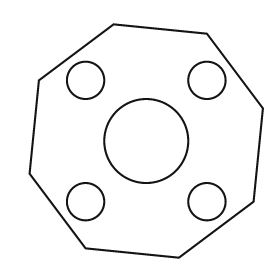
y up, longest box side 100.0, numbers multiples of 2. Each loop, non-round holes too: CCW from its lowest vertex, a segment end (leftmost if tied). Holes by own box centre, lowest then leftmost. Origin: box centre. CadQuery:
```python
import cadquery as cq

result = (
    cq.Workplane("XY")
    .moveTo(14.0, -50.0)
    .lineTo(46.0, -26.0)
    .lineTo(50.0, 14.0)
    .lineTo(26.0, 46.0)
    .lineTo(-14.0, 50.0)
    .lineTo(-46.0, 26.0)
    .lineTo(-50.0, -14.0)
    .lineTo(-26.0, -46.0)
    .close()
    .moveTo(-26.0, -26.0)
    .circle(8.0)
    .moveTo(26.0, -26.0)
    .circle(8.0)
    .moveTo(0.0, 0.0)
    .circle(18.0)
    .moveTo(-26.0, 26.0)
    .circle(8.0)
    .moveTo(26.0, 26.0)
    .circle(8.0)
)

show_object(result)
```